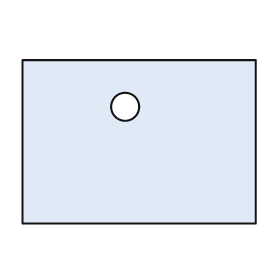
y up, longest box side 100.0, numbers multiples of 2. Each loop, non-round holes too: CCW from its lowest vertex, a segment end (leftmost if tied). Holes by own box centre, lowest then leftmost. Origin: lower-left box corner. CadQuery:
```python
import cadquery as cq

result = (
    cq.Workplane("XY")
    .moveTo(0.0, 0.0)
    .lineTo(100.0, 0.0)
    .lineTo(100.0, 70.0)
    .lineTo(0.0, 70.0)
    .close()
    .moveTo(44.0, 50.0)
    .circle(6.0)
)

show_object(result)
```